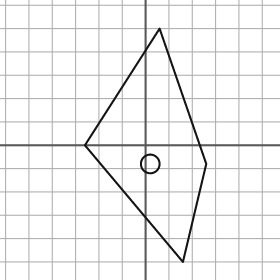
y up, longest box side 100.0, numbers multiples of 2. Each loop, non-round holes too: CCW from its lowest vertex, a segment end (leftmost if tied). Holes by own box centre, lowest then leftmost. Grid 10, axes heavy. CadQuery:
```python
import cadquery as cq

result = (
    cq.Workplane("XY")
    .moveTo(16.0, -50.0)
    .lineTo(26.0, -8.0)
    .lineTo(6.0, 50.0)
    .lineTo(-26.0, 0.0)
    .close()
    .moveTo(2.0, -8.0)
    .circle(4.0)
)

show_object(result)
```